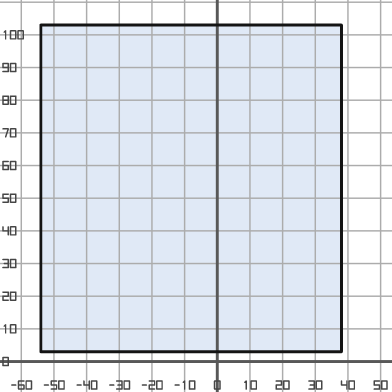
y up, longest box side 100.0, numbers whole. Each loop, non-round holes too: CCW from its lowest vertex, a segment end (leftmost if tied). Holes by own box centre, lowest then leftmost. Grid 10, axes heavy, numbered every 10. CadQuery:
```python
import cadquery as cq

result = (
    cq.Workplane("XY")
    .moveTo(-54.0, 3.0)
    .lineTo(38.0, 3.0)
    .lineTo(38.0, 103.0)
    .lineTo(-54.0, 103.0)
    .close()
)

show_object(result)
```